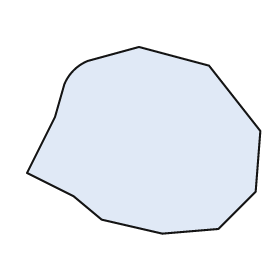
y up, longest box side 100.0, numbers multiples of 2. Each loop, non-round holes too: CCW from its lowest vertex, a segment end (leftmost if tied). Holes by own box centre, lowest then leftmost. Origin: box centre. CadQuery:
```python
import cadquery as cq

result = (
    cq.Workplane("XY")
    .moveTo(8.0, -40.0)
    .lineTo(32.0, -38.0)
    .lineTo(48.0, -22.0)
    .lineTo(50.0, 4.0)
    .lineTo(28.0, 32.0)
    .lineTo(-2.0, 40.0)
    .lineTo(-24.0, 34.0)
    .threePointArc((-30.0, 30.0), (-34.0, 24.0))
    .lineTo(-38.0, 10.0)
    .lineTo(-50.0, -14.0)
    .lineTo(-30.0, -24.0)
    .lineTo(-18.0, -34.0)
    .close()
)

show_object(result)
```